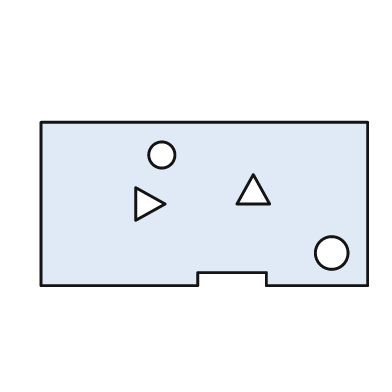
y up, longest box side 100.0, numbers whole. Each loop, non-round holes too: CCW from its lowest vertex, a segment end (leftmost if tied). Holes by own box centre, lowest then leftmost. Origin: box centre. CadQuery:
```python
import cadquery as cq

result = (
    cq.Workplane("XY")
    .moveTo(-50.0, -25.0)
    .lineTo(-2.0, -25.0)
    .lineTo(-2.0, -21.0)
    .lineTo(19.0, -21.0)
    .lineTo(19.0, -25.0)
    .lineTo(50.0, -25.0)
    .lineTo(50.0, 25.0)
    .lineTo(-50.0, 25.0)
    .close()
    .moveTo(39.0, -15.0)
    .circle(5.0)
    .moveTo(-21.0, -5.0)
    .lineTo(-12.0, 0.0)
    .lineTo(-21.0, 5.0)
    .close()
    .moveTo(10.0, 0.0)
    .lineTo(20.0, 0.0)
    .lineTo(15.0, 9.0)
    .close()
    .moveTo(-13.0, 15.0)
    .circle(4.0)
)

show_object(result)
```